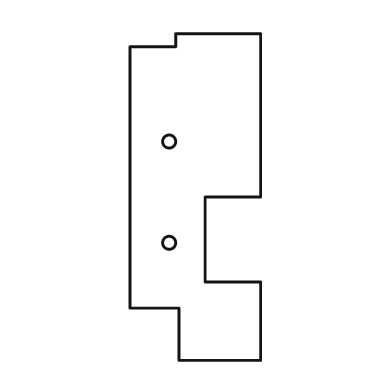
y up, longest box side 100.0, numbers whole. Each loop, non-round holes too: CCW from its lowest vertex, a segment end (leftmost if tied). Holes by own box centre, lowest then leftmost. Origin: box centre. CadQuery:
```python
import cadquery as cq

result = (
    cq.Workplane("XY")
    .moveTo(-5.0, -50.0)
    .lineTo(20.0, -50.0)
    .lineTo(20.0, -26.0)
    .lineTo(3.0, -26.0)
    .lineTo(3.0, 0.0)
    .lineTo(20.0, 0.0)
    .lineTo(20.0, 50.0)
    .lineTo(-6.0, 50.0)
    .lineTo(-6.0, 46.0)
    .lineTo(-20.0, 46.0)
    .lineTo(-20.0, -34.0)
    .lineTo(-5.0, -34.0)
    .close()
    .moveTo(-8.0, -14.0)
    .circle(2.0)
    .moveTo(-8.0, 17.0)
    .circle(2.0)
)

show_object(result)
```